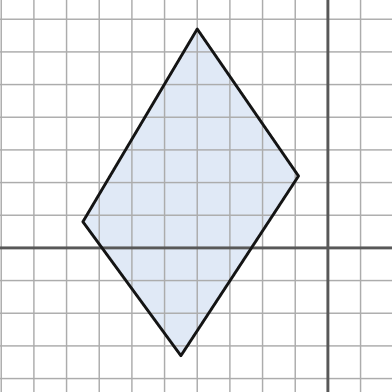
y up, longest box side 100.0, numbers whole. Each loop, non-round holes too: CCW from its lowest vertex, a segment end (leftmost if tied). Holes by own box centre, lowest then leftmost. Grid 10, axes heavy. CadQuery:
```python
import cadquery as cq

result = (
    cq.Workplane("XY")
    .moveTo(-45.0, -33.0)
    .lineTo(-9.0, 22.0)
    .lineTo(-40.0, 67.0)
    .lineTo(-75.0, 8.0)
    .close()
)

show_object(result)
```